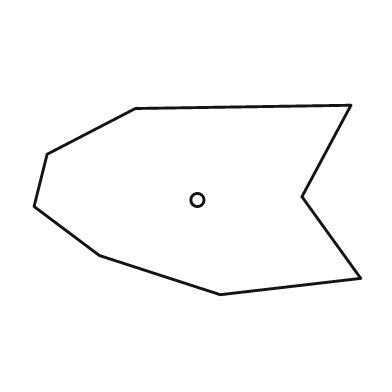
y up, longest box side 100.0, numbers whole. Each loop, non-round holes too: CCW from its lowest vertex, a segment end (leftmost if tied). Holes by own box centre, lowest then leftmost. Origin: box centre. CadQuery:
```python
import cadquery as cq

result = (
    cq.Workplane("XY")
    .moveTo(7.0, -29.0)
    .lineTo(50.0, -24.0)
    .lineTo(32.0, 1.0)
    .lineTo(47.0, 29.0)
    .lineTo(-19.0, 28.0)
    .lineTo(-46.0, 14.0)
    .lineTo(-50.0, -2.0)
    .lineTo(-30.0, -17.0)
    .close()
    .moveTo(0.0, 0.0)
    .circle(2.0)
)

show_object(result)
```